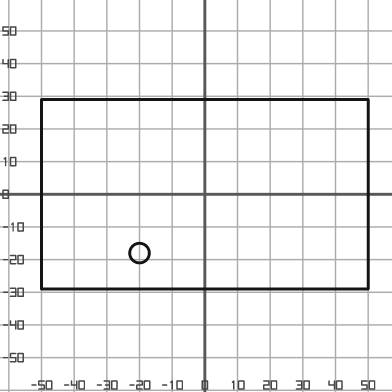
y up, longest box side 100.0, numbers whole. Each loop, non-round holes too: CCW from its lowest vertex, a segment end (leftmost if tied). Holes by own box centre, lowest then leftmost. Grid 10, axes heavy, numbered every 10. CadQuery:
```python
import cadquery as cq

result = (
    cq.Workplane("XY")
    .moveTo(-50.0, -29.0)
    .lineTo(50.0, -29.0)
    .lineTo(50.0, 29.0)
    .lineTo(-50.0, 29.0)
    .close()
    .moveTo(-20.0, -18.0)
    .circle(3.0)
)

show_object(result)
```